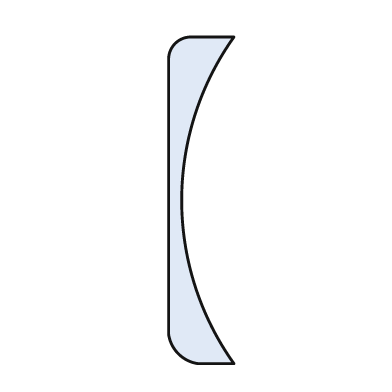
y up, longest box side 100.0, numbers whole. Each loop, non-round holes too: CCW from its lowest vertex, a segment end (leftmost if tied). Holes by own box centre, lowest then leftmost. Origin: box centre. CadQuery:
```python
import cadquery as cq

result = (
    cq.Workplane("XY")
    .moveTo(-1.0, -50.0)
    .lineTo(10.0, -50.0)
    .threePointArc((-6.0, 0.0), (10.0, 50.0))
    .lineTo(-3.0, 50.0)
    .threePointArc((-8.0, 48.0), (-10.0, 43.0))
    .lineTo(-10.0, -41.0)
    .threePointArc((-7.0, -47.0), (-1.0, -50.0))
    .close()
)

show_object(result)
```